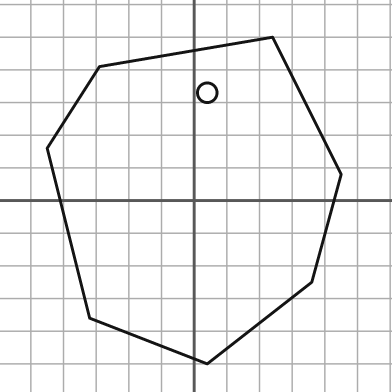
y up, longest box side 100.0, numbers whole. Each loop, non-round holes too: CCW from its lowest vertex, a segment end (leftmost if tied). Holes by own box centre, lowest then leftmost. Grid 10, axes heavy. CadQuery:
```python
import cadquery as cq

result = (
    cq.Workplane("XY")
    .moveTo(4.0, -50.0)
    .lineTo(36.0, -25.0)
    .lineTo(45.0, 8.0)
    .lineTo(24.0, 50.0)
    .lineTo(-29.0, 41.0)
    .lineTo(-45.0, 16.0)
    .lineTo(-32.0, -36.0)
    .close()
    .moveTo(4.0, 33.0)
    .circle(3.0)
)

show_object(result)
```